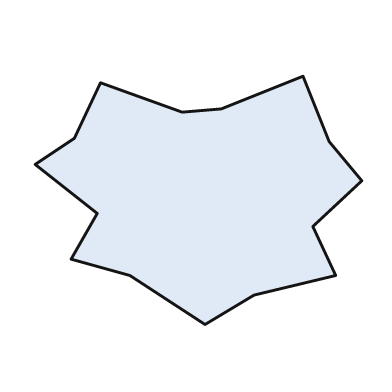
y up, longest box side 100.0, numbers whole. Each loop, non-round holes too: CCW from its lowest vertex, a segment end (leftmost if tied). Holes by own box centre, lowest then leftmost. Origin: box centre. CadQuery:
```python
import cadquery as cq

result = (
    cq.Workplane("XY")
    .moveTo(2.0, -38.0)
    .lineTo(17.0, -29.0)
    .lineTo(42.0, -23.0)
    .lineTo(35.0, -8.0)
    .lineTo(50.0, 6.0)
    .lineTo(40.0, 18.0)
    .lineTo(32.0, 38.0)
    .lineTo(7.0, 28.0)
    .lineTo(-5.0, 27.0)
    .lineTo(-30.0, 36.0)
    .lineTo(-38.0, 19.0)
    .lineTo(-50.0, 11.0)
    .lineTo(-31.0, -4.0)
    .lineTo(-39.0, -18.0)
    .lineTo(-21.0, -23.0)
    .close()
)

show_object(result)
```